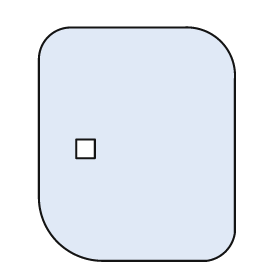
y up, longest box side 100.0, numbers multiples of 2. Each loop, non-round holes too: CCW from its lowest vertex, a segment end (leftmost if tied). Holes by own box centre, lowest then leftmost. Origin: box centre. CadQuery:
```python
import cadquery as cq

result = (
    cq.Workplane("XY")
    .moveTo(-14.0, -50.0)
    .lineTo(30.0, -50.0)
    .threePointArc((38.0, -46.0), (42.0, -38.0))
    .lineTo(42.0, 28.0)
    .threePointArc((36.0, 44.0), (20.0, 50.0))
    .lineTo(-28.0, 50.0)
    .threePointArc((-38.0, 46.0), (-42.0, 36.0))
    .lineTo(-42.0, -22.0)
    .threePointArc((-34.0, -42.0), (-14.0, -50.0))
    .close()
    .moveTo(-26.0, -6.0)
    .lineTo(-18.0, -6.0)
    .lineTo(-18.0, 2.0)
    .lineTo(-26.0, 2.0)
    .close()
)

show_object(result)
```